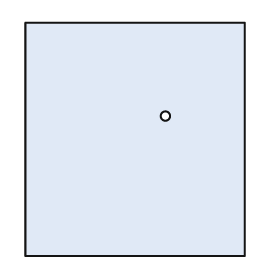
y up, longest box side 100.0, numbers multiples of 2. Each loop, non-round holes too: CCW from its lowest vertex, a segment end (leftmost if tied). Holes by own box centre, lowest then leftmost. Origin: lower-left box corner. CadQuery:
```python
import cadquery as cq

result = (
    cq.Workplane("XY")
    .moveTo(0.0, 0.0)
    .lineTo(94.0, 0.0)
    .lineTo(94.0, 100.0)
    .lineTo(0.0, 100.0)
    .close()
    .moveTo(60.0, 60.0)
    .circle(2.0)
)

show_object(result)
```